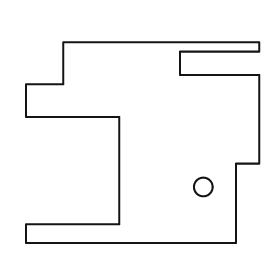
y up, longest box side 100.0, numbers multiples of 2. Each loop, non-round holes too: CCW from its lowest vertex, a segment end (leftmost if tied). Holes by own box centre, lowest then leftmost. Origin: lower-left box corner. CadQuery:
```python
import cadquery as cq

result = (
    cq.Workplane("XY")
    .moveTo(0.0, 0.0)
    .lineTo(90.0, 0.0)
    .lineTo(90.0, 34.0)
    .lineTo(100.0, 34.0)
    .lineTo(100.0, 72.0)
    .lineTo(66.0, 72.0)
    .lineTo(66.0, 82.0)
    .lineTo(100.0, 82.0)
    .lineTo(100.0, 86.0)
    .lineTo(16.0, 86.0)
    .lineTo(16.0, 68.0)
    .lineTo(0.0, 68.0)
    .lineTo(0.0, 54.0)
    .lineTo(40.0, 54.0)
    .lineTo(40.0, 8.0)
    .lineTo(0.0, 8.0)
    .close()
    .moveTo(76.0, 24.0)
    .circle(4.0)
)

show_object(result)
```